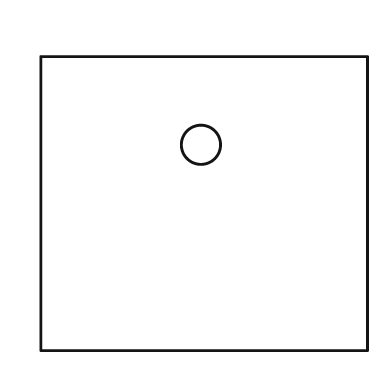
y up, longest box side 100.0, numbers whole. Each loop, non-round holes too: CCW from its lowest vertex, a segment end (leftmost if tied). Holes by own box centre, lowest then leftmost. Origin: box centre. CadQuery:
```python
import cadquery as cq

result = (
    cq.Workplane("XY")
    .moveTo(-50.0, -45.0)
    .lineTo(50.0, -45.0)
    .lineTo(50.0, 45.0)
    .lineTo(-50.0, 45.0)
    .close()
    .moveTo(-1.0, 18.0)
    .circle(6.0)
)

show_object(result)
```